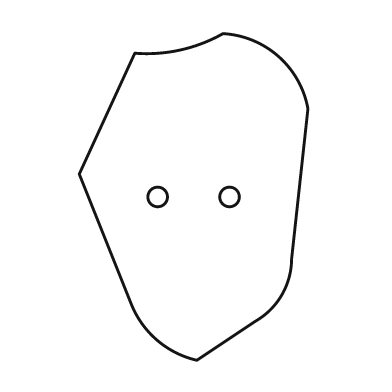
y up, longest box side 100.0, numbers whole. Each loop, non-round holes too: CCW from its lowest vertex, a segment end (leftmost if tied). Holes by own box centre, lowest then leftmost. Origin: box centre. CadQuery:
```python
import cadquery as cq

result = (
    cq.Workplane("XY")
    .moveTo(1.0, -50.0)
    .lineTo(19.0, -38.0)
    .threePointArc((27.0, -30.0), (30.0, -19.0))
    .lineTo(35.0, 27.0)
    .threePointArc((26.0, 43.0), (9.0, 50.0))
    .threePointArc((-4.0, 45.0), (-18.0, 44.0))
    .lineTo(-35.0, 7.0)
    .lineTo(-19.0, -33.0)
    .threePointArc((-11.0, -44.0), (1.0, -50.0))
    .close()
    .moveTo(-11.0, 0.0)
    .circle(3.0)
    .moveTo(11.0, 0.0)
    .circle(3.0)
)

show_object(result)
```